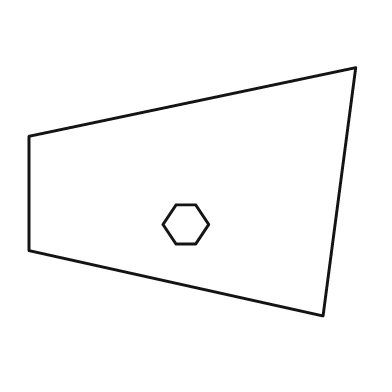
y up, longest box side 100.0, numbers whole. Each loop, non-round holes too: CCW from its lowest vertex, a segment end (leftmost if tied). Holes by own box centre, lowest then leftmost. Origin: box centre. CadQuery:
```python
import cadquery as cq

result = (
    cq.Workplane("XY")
    .moveTo(40.0, -38.0)
    .lineTo(50.0, 38.0)
    .lineTo(-50.0, 17.0)
    .lineTo(-50.0, -18.0)
    .close()
    .moveTo(-5.0, -16.0)
    .lineTo(1.0, -16.0)
    .lineTo(5.0, -10.0)
    .lineTo(1.0, -4.0)
    .lineTo(-5.0, -4.0)
    .lineTo(-9.0, -10.0)
    .close()
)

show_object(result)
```